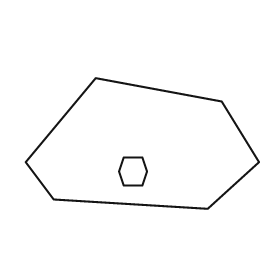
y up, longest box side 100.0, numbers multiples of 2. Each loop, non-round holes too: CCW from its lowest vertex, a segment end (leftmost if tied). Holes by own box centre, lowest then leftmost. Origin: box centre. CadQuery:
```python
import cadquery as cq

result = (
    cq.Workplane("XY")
    .moveTo(28.0, -28.0)
    .lineTo(50.0, -8.0)
    .lineTo(34.0, 18.0)
    .lineTo(-20.0, 28.0)
    .lineTo(-50.0, -8.0)
    .lineTo(-38.0, -24.0)
    .close()
    .moveTo(-8.0, -18.0)
    .lineTo(0.0, -18.0)
    .lineTo(2.0, -12.0)
    .lineTo(0.0, -6.0)
    .lineTo(-8.0, -6.0)
    .lineTo(-10.0, -12.0)
    .close()
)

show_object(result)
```